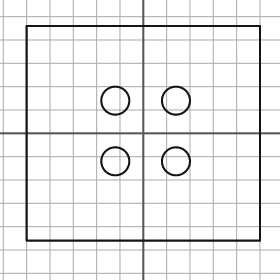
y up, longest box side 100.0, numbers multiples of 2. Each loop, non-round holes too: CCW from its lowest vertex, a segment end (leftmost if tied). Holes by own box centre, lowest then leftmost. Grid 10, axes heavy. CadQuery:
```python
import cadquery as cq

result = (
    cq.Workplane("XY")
    .moveTo(-50.0, -46.0)
    .lineTo(50.0, -46.0)
    .lineTo(50.0, 46.0)
    .lineTo(-50.0, 46.0)
    .close()
    .moveTo(-12.0, -12.0)
    .circle(6.0)
    .moveTo(14.0, -12.0)
    .circle(6.0)
    .moveTo(-12.0, 14.0)
    .circle(6.0)
    .moveTo(14.0, 14.0)
    .circle(6.0)
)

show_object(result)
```